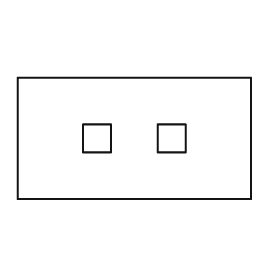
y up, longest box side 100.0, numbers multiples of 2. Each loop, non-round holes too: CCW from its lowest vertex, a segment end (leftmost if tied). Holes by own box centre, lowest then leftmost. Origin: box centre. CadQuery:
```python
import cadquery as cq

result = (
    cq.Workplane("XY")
    .moveTo(-50.0, -26.0)
    .lineTo(50.0, -26.0)
    .lineTo(50.0, 26.0)
    .lineTo(-50.0, 26.0)
    .close()
    .moveTo(-22.0, -6.0)
    .lineTo(-10.0, -6.0)
    .lineTo(-10.0, 6.0)
    .lineTo(-22.0, 6.0)
    .close()
    .moveTo(10.0, -6.0)
    .lineTo(22.0, -6.0)
    .lineTo(22.0, 6.0)
    .lineTo(10.0, 6.0)
    .close()
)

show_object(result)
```